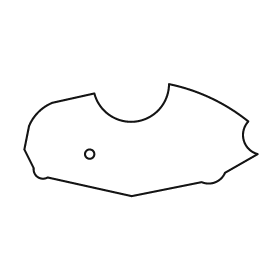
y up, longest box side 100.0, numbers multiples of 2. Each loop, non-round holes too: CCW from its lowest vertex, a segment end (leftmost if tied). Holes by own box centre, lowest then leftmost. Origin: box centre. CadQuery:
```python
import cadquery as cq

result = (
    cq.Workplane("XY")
    .moveTo(-4.0, -24.0)
    .lineTo(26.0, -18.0)
    .threePointArc((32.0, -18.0), (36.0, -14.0))
    .lineTo(50.0, -6.0)
    .threePointArc((44.0, 0.0), (46.0, 8.0))
    .threePointArc((30.0, 18.0), (12.0, 24.0))
    .threePointArc((-2.0, 8.0), (-20.0, 20.0))
    .lineTo(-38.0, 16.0)
    .threePointArc((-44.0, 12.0), (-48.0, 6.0))
    .lineTo(-50.0, -4.0)
    .lineTo(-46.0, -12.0)
    .threePointArc((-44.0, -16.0), (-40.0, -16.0))
    .close()
    .moveTo(-22.0, -6.0)
    .circle(2.0)
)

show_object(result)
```